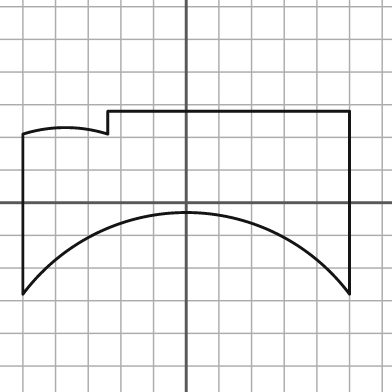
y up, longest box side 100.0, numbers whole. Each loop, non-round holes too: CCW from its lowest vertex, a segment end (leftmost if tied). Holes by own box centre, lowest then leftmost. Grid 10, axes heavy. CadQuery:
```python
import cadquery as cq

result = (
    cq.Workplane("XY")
    .moveTo(-50.0, -28.0)
    .threePointArc((0.0, -3.0), (50.0, -28.0))
    .lineTo(50.0, 28.0)
    .lineTo(-24.0, 28.0)
    .lineTo(-24.0, 21.0)
    .threePointArc((-37.0, 23.0), (-50.0, 21.0))
    .close()
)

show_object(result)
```